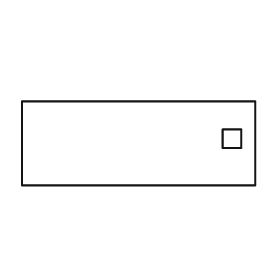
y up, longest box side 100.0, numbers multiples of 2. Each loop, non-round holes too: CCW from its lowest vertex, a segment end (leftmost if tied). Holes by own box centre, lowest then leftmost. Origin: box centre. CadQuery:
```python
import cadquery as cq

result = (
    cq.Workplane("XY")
    .moveTo(-50.0, -18.0)
    .lineTo(50.0, -18.0)
    .lineTo(50.0, 18.0)
    .lineTo(-50.0, 18.0)
    .close()
    .moveTo(36.0, -2.0)
    .lineTo(44.0, -2.0)
    .lineTo(44.0, 6.0)
    .lineTo(36.0, 6.0)
    .close()
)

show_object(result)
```